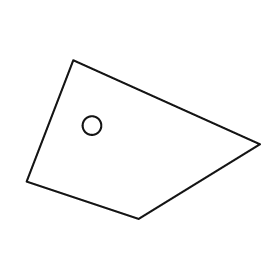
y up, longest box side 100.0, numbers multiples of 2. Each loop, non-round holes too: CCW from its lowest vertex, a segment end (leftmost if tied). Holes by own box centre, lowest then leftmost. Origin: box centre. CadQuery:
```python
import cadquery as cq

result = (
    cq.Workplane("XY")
    .moveTo(-2.0, -34.0)
    .lineTo(50.0, -2.0)
    .lineTo(-30.0, 34.0)
    .lineTo(-50.0, -18.0)
    .close()
    .moveTo(-22.0, 6.0)
    .circle(4.0)
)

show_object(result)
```